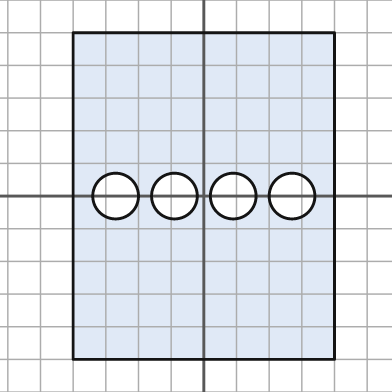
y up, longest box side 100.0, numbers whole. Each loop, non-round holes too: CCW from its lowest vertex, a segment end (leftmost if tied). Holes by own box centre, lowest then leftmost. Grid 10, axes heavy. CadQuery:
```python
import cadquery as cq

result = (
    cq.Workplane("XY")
    .moveTo(-40.0, -50.0)
    .lineTo(40.0, -50.0)
    .lineTo(40.0, 50.0)
    .lineTo(-40.0, 50.0)
    .close()
    .moveTo(-27.0, 0.0)
    .circle(7.0)
    .moveTo(-9.0, 0.0)
    .circle(7.0)
    .moveTo(9.0, 0.0)
    .circle(7.0)
    .moveTo(27.0, 0.0)
    .circle(7.0)
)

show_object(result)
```